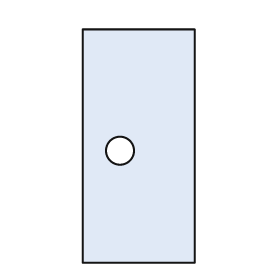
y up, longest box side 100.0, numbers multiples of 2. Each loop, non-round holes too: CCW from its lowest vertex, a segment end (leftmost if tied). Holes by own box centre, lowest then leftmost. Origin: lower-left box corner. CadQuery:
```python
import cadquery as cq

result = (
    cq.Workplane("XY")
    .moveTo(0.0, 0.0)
    .lineTo(48.0, 0.0)
    .lineTo(48.0, 100.0)
    .lineTo(0.0, 100.0)
    .close()
    .moveTo(16.0, 48.0)
    .circle(6.0)
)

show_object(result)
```